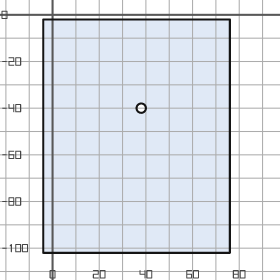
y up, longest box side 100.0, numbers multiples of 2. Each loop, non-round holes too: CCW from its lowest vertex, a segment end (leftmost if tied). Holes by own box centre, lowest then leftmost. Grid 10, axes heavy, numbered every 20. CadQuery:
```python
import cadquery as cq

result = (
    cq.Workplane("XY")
    .moveTo(-4.0, -102.0)
    .lineTo(76.0, -102.0)
    .lineTo(76.0, -2.0)
    .lineTo(-4.0, -2.0)
    .close()
    .moveTo(38.0, -40.0)
    .circle(2.0)
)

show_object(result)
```